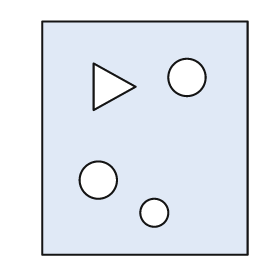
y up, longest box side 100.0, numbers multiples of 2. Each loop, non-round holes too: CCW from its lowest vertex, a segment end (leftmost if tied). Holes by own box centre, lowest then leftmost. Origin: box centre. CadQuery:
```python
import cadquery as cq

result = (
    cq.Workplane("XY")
    .moveTo(-44.0, -50.0)
    .lineTo(44.0, -50.0)
    .lineTo(44.0, 50.0)
    .lineTo(-44.0, 50.0)
    .close()
    .moveTo(4.0, -32.0)
    .circle(6.0)
    .moveTo(-20.0, -18.0)
    .circle(8.0)
    .moveTo(-22.0, 12.0)
    .lineTo(-4.0, 22.0)
    .lineTo(-22.0, 32.0)
    .close()
    .moveTo(18.0, 26.0)
    .circle(8.0)
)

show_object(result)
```